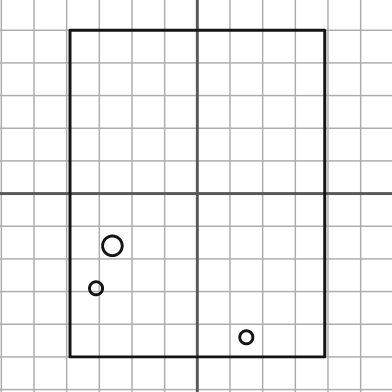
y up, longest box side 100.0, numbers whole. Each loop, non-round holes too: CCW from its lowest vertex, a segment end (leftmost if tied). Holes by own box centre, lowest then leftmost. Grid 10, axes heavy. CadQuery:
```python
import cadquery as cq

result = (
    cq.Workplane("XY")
    .moveTo(-39.0, -50.0)
    .lineTo(39.0, -50.0)
    .lineTo(39.0, 50.0)
    .lineTo(-39.0, 50.0)
    .close()
    .moveTo(15.0, -44.0)
    .circle(2.0)
    .moveTo(-31.0, -29.0)
    .circle(2.0)
    .moveTo(-26.0, -16.0)
    .circle(3.0)
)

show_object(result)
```